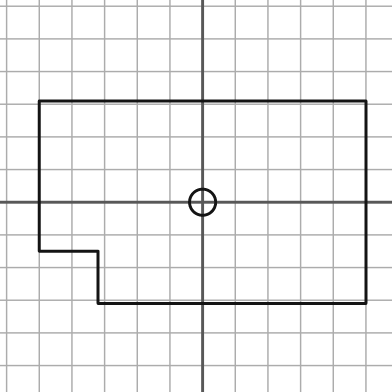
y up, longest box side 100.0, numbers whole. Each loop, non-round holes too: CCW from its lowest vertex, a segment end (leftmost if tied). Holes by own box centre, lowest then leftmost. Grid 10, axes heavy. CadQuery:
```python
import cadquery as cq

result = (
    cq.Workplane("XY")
    .moveTo(-32.0, -31.0)
    .lineTo(50.0, -31.0)
    .lineTo(50.0, 31.0)
    .lineTo(-50.0, 31.0)
    .lineTo(-50.0, -15.0)
    .lineTo(-32.0, -15.0)
    .close()
    .moveTo(0.0, 0.0)
    .circle(4.0)
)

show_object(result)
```